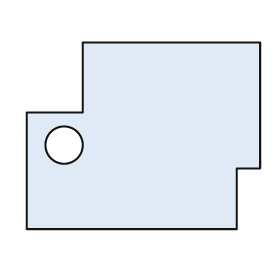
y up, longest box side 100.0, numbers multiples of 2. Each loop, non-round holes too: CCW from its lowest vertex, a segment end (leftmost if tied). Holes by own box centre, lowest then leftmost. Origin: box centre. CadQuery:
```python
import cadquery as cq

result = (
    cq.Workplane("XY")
    .moveTo(-50.0, -40.0)
    .lineTo(40.0, -40.0)
    .lineTo(40.0, -14.0)
    .lineTo(50.0, -14.0)
    .lineTo(50.0, 40.0)
    .lineTo(-26.0, 40.0)
    .lineTo(-26.0, 10.0)
    .lineTo(-50.0, 10.0)
    .close()
    .moveTo(-34.0, -4.0)
    .circle(8.0)
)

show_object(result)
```